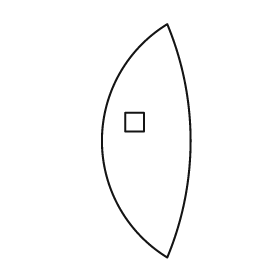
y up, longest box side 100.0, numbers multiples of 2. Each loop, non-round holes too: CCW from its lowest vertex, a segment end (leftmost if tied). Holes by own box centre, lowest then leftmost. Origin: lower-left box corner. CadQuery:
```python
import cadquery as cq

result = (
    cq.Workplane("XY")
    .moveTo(28.0, 0.0)
    .threePointArc((38.0, 50.0), (28.0, 100.0))
    .threePointArc((0.0, 50.0), (28.0, 0.0))
    .close()
    .moveTo(10.0, 54.0)
    .lineTo(18.0, 54.0)
    .lineTo(18.0, 62.0)
    .lineTo(10.0, 62.0)
    .close()
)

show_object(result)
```